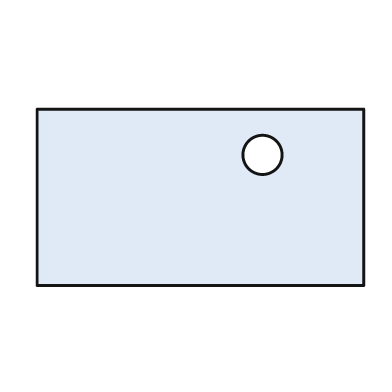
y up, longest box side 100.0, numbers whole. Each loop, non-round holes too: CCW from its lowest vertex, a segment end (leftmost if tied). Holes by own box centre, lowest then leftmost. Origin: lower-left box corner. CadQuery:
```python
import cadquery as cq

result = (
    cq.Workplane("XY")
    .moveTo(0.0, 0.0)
    .lineTo(100.0, 0.0)
    .lineTo(100.0, 54.0)
    .lineTo(0.0, 54.0)
    .close()
    .moveTo(69.0, 40.0)
    .circle(6.0)
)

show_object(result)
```